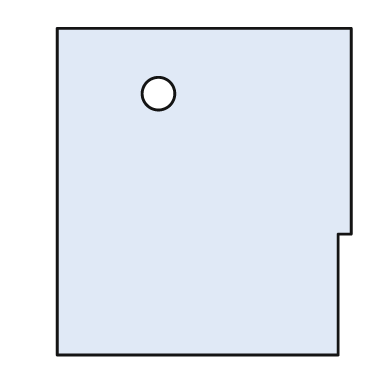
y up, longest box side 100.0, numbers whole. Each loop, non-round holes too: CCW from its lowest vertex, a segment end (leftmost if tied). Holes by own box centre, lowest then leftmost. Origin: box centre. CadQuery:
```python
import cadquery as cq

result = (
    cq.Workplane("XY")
    .moveTo(-45.0, -50.0)
    .lineTo(41.0, -50.0)
    .lineTo(41.0, -13.0)
    .lineTo(45.0, -13.0)
    .lineTo(45.0, 50.0)
    .lineTo(-45.0, 50.0)
    .close()
    .moveTo(-14.0, 30.0)
    .circle(5.0)
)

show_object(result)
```